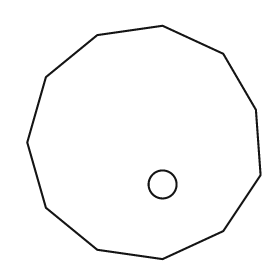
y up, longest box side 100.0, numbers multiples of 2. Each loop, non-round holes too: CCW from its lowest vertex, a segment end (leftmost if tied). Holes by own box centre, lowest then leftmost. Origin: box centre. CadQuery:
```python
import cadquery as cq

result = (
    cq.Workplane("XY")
    .moveTo(8.0, -50.0)
    .lineTo(34.0, -38.0)
    .lineTo(50.0, -14.0)
    .lineTo(48.0, 14.0)
    .lineTo(34.0, 38.0)
    .lineTo(8.0, 50.0)
    .lineTo(-20.0, 46.0)
    .lineTo(-42.0, 28.0)
    .lineTo(-50.0, 0.0)
    .lineTo(-42.0, -28.0)
    .lineTo(-20.0, -46.0)
    .close()
    .moveTo(8.0, -18.0)
    .circle(6.0)
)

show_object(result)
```